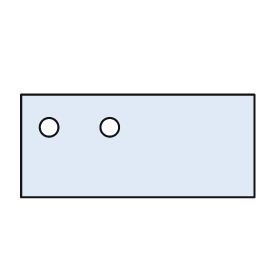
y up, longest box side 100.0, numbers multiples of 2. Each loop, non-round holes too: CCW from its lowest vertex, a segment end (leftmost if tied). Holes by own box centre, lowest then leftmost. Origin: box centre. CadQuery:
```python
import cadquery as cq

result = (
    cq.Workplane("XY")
    .moveTo(-50.0, -22.0)
    .lineTo(50.0, -22.0)
    .lineTo(50.0, 22.0)
    .lineTo(-50.0, 22.0)
    .close()
    .moveTo(-38.0, 8.0)
    .circle(4.0)
    .moveTo(-12.0, 8.0)
    .circle(4.0)
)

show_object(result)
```